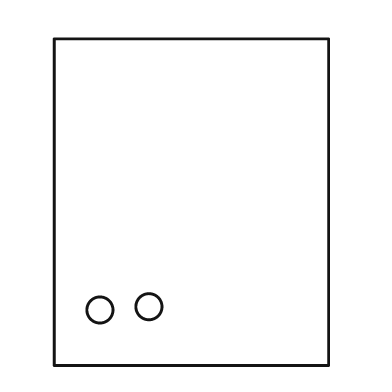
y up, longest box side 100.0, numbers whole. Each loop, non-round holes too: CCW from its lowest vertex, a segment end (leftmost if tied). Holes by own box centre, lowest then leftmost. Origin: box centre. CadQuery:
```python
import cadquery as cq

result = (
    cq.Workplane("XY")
    .moveTo(-42.0, -50.0)
    .lineTo(42.0, -50.0)
    .lineTo(42.0, 50.0)
    .lineTo(-42.0, 50.0)
    .close()
    .moveTo(-28.0, -33.0)
    .circle(4.0)
    .moveTo(-13.0, -32.0)
    .circle(4.0)
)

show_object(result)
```